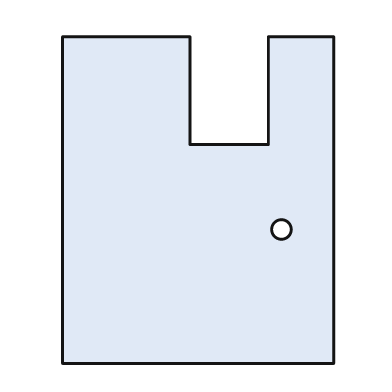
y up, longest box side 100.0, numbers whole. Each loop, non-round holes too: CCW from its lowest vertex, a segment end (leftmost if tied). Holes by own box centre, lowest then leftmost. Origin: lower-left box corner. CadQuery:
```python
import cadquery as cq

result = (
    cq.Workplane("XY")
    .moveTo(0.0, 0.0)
    .lineTo(83.0, 0.0)
    .lineTo(83.0, 100.0)
    .lineTo(63.0, 100.0)
    .lineTo(63.0, 67.0)
    .lineTo(39.0, 67.0)
    .lineTo(39.0, 100.0)
    .lineTo(0.0, 100.0)
    .close()
    .moveTo(67.0, 41.0)
    .circle(3.0)
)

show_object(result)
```